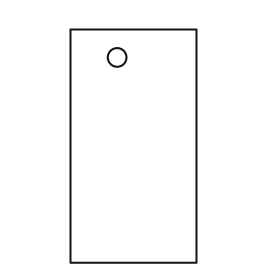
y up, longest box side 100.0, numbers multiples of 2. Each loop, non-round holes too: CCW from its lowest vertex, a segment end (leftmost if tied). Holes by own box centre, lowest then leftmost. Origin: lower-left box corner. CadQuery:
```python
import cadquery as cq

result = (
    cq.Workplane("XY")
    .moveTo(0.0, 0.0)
    .lineTo(54.0, 0.0)
    .lineTo(54.0, 100.0)
    .lineTo(0.0, 100.0)
    .close()
    .moveTo(20.0, 88.0)
    .circle(4.0)
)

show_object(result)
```